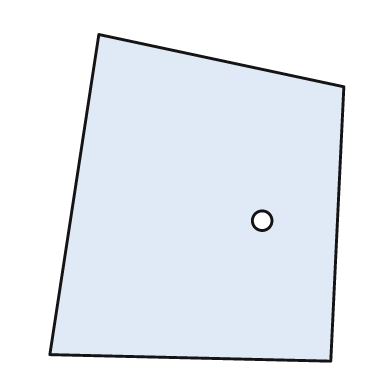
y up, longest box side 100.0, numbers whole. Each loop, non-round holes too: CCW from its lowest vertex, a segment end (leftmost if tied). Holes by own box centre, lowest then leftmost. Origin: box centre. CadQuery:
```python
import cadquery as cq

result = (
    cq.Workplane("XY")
    .moveTo(41.0, -50.0)
    .lineTo(45.0, 34.0)
    .lineTo(-30.0, 50.0)
    .lineTo(-45.0, -48.0)
    .close()
    .moveTo(20.0, -7.0)
    .circle(3.0)
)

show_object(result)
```